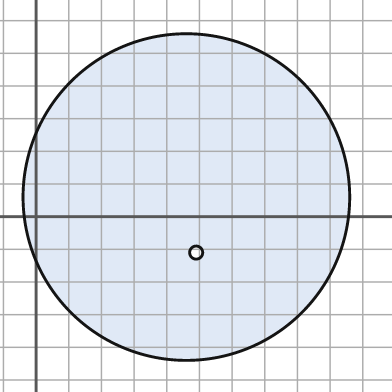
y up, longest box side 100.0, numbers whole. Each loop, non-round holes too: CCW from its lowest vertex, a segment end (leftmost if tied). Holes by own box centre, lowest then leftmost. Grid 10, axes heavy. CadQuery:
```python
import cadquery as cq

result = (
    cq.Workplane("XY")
    .moveTo(46.0, 6.0)
    .circle(50.0)
    .moveTo(49.0, -11.0)
    .circle(2.0)
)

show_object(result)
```